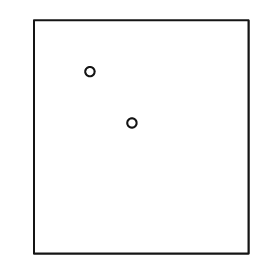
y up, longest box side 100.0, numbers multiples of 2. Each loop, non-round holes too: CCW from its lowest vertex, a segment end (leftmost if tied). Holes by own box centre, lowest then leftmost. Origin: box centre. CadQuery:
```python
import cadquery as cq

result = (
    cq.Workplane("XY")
    .moveTo(-46.0, -50.0)
    .lineTo(46.0, -50.0)
    .lineTo(46.0, 50.0)
    .lineTo(-46.0, 50.0)
    .close()
    .moveTo(-4.0, 6.0)
    .circle(2.0)
    .moveTo(-22.0, 28.0)
    .circle(2.0)
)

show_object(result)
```